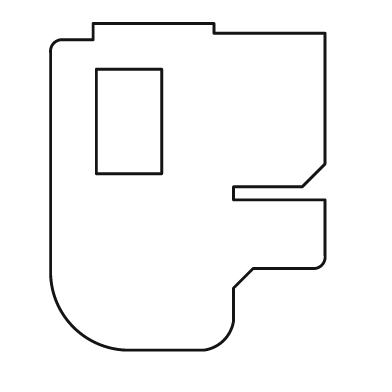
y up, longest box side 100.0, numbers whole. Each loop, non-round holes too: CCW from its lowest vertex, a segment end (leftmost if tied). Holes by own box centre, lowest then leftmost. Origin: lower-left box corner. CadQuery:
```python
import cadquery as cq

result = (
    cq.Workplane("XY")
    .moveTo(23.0, 0.0)
    .lineTo(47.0, 0.0)
    .threePointArc((53.0, 3.0), (56.0, 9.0))
    .lineTo(56.0, 19.0)
    .lineTo(62.0, 25.0)
    .lineTo(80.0, 25.0)
    .threePointArc((83.0, 26.0), (84.0, 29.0))
    .lineTo(84.0, 46.0)
    .lineTo(56.0, 46.0)
    .lineTo(56.0, 50.0)
    .lineTo(77.0, 50.0)
    .lineTo(84.0, 57.0)
    .lineTo(84.0, 97.0)
    .lineTo(50.0, 97.0)
    .lineTo(50.0, 100.0)
    .lineTo(13.0, 100.0)
    .lineTo(13.0, 95.0)
    .lineTo(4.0, 95.0)
    .threePointArc((1.0, 94.0), (0.0, 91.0))
    .lineTo(0.0, 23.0)
    .threePointArc((7.0, 7.0), (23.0, 0.0))
    .close()
    .moveTo(14.0, 54.0)
    .lineTo(34.0, 54.0)
    .lineTo(34.0, 86.0)
    .lineTo(14.0, 86.0)
    .close()
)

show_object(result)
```